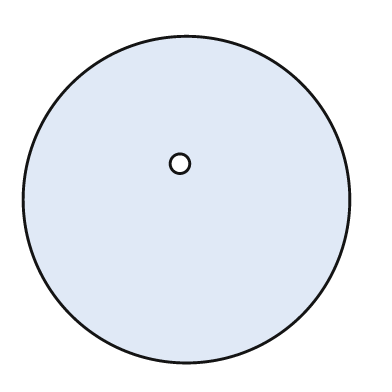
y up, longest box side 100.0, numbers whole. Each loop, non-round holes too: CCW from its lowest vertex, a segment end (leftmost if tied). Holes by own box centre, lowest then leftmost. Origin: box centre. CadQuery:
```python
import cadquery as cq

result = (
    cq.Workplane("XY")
    .moveTo(0.0, 0.0)
    .circle(50.0)
    .moveTo(-2.0, 11.0)
    .circle(3.0)
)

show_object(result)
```